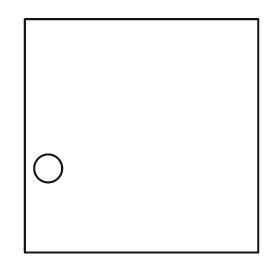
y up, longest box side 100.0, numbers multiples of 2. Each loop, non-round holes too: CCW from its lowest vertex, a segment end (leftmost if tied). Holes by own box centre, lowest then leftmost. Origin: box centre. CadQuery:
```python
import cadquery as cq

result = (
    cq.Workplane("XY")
    .moveTo(-50.0, -50.0)
    .lineTo(50.0, -50.0)
    .lineTo(50.0, 50.0)
    .lineTo(-50.0, 50.0)
    .close()
    .moveTo(-40.0, -14.0)
    .circle(6.0)
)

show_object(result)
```